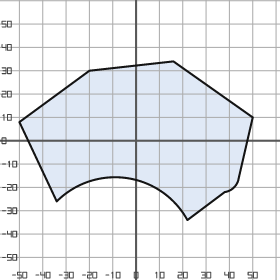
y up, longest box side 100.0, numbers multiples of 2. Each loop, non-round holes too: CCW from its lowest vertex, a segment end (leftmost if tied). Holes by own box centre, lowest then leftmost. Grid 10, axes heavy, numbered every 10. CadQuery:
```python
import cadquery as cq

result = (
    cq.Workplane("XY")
    .moveTo(22.0, -34.0)
    .lineTo(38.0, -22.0)
    .threePointArc((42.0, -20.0), (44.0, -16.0))
    .lineTo(50.0, 10.0)
    .lineTo(16.0, 34.0)
    .lineTo(-20.0, 30.0)
    .lineTo(-50.0, 8.0)
    .lineTo(-34.0, -26.0)
    .threePointArc((-4.0, -16.0), (22.0, -34.0))
    .close()
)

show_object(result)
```